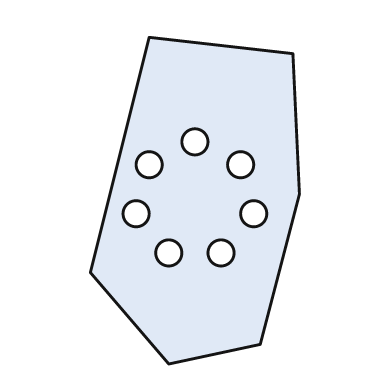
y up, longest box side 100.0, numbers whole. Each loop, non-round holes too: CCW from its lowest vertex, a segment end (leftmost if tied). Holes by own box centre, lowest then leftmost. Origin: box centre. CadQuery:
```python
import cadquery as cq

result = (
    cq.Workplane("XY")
    .moveTo(-8.0, -50.0)
    .lineTo(20.0, -44.0)
    .lineTo(32.0, 2.0)
    .lineTo(30.0, 45.0)
    .lineTo(-14.0, 50.0)
    .lineTo(-32.0, -22.0)
    .close()
    .moveTo(-8.0, -16.0)
    .circle(4.0)
    .moveTo(8.0, -16.0)
    .circle(4.0)
    .moveTo(-18.0, -4.0)
    .circle(4.0)
    .moveTo(18.0, -4.0)
    .circle(4.0)
    .moveTo(-14.0, 11.0)
    .circle(4.0)
    .moveTo(14.0, 11.0)
    .circle(4.0)
    .moveTo(0.0, 18.0)
    .circle(4.0)
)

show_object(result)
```